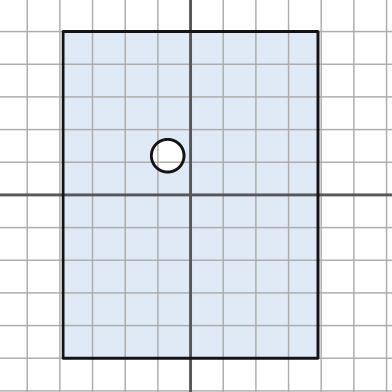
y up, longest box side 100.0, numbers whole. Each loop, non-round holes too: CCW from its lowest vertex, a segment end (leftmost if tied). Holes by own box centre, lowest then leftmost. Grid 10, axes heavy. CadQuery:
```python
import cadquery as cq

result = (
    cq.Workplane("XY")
    .moveTo(-39.0, -50.0)
    .lineTo(39.0, -50.0)
    .lineTo(39.0, 50.0)
    .lineTo(-39.0, 50.0)
    .close()
    .moveTo(-7.0, 12.0)
    .circle(5.0)
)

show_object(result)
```